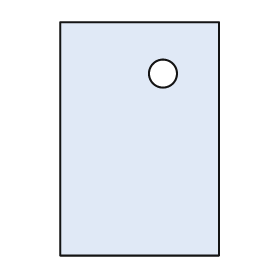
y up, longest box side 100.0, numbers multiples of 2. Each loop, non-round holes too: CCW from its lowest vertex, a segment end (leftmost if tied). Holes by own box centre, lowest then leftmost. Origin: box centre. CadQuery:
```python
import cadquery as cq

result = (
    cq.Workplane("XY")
    .moveTo(-34.0, -50.0)
    .lineTo(34.0, -50.0)
    .lineTo(34.0, 50.0)
    .lineTo(-34.0, 50.0)
    .close()
    .moveTo(10.0, 28.0)
    .circle(6.0)
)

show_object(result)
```